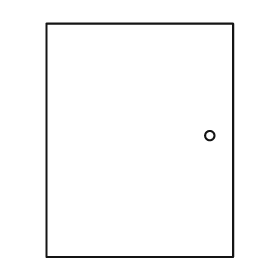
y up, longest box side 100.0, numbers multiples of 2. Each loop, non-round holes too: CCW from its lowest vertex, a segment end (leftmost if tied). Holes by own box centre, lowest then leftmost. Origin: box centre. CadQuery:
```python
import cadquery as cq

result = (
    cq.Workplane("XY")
    .moveTo(-40.0, -50.0)
    .lineTo(40.0, -50.0)
    .lineTo(40.0, 50.0)
    .lineTo(-40.0, 50.0)
    .close()
    .moveTo(30.0, 2.0)
    .circle(2.0)
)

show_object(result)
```